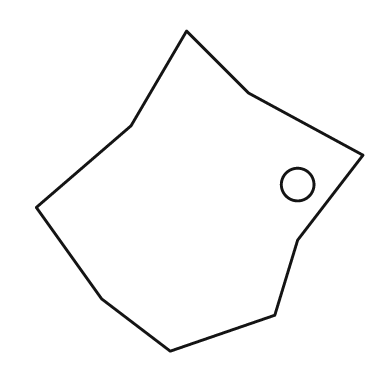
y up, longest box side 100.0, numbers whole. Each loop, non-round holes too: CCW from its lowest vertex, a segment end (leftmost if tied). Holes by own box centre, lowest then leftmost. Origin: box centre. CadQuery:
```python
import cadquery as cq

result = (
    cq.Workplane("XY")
    .moveTo(-9.0, -49.0)
    .lineTo(23.0, -38.0)
    .lineTo(30.0, -15.0)
    .lineTo(50.0, 11.0)
    .lineTo(15.0, 30.0)
    .lineTo(-4.0, 49.0)
    .lineTo(-21.0, 20.0)
    .lineTo(-50.0, -5.0)
    .lineTo(-30.0, -33.0)
    .close()
    .moveTo(30.0, 2.0)
    .circle(5.0)
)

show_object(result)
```